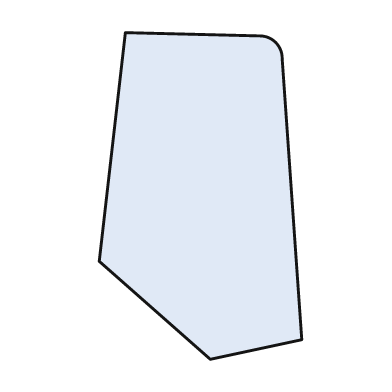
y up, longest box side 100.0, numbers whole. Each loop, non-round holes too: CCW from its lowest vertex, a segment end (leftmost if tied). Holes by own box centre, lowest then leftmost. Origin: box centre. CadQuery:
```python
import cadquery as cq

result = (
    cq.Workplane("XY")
    .moveTo(3.0, -50.0)
    .lineTo(31.0, -44.0)
    .lineTo(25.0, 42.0)
    .threePointArc((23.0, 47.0), (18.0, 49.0))
    .lineTo(-23.0, 50.0)
    .lineTo(-31.0, -20.0)
    .close()
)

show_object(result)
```